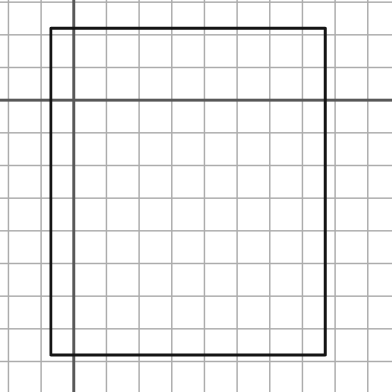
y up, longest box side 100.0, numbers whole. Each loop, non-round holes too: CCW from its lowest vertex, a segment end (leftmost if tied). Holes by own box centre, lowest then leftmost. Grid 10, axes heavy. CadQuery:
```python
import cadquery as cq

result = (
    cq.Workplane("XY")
    .moveTo(-7.0, -78.0)
    .lineTo(77.0, -78.0)
    .lineTo(77.0, 22.0)
    .lineTo(-7.0, 22.0)
    .close()
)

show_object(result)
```